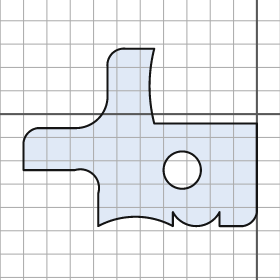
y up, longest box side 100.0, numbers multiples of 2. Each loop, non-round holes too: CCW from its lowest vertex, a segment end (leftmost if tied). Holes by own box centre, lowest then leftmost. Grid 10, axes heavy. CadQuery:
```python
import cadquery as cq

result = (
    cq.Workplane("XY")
    .moveTo(-68.0, -48.0)
    .threePointArc((-52.0, -44.0), (-36.0, -48.0))
    .lineTo(-36.0, -42.0)
    .threePointArc((-26.0, -48.0), (-16.0, -42.0))
    .lineTo(-16.0, -48.0)
    .lineTo(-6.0, -48.0)
    .threePointArc((-2.0, -46.0), (0.0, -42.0))
    .lineTo(0.0, -4.0)
    .lineTo(-44.0, -4.0)
    .threePointArc((-46.0, 12.0), (-44.0, 28.0))
    .lineTo(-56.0, 28.0)
    .threePointArc((-62.0, 26.0), (-64.0, 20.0))
    .lineTo(-64.0, 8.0)
    .threePointArc((-68.0, -2.0), (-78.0, -6.0))
    .lineTo(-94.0, -6.0)
    .threePointArc((-98.0, -8.0), (-100.0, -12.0))
    .lineTo(-100.0, -24.0)
    .lineTo(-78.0, -24.0)
    .threePointArc((-70.0, -26.0), (-68.0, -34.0))
    .close()
    .moveTo(-32.0, -24.0)
    .circle(8.0)
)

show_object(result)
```